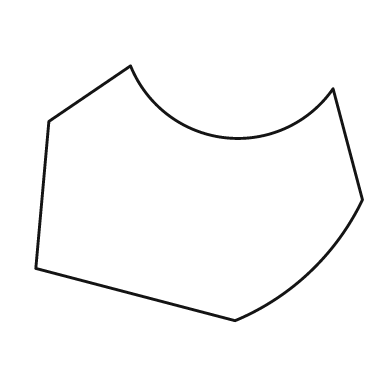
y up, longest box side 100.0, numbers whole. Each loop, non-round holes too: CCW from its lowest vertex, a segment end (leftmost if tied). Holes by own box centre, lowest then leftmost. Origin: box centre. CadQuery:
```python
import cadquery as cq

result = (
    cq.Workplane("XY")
    .moveTo(11.0, -39.0)
    .threePointArc((34.0, -24.0), (50.0, -2.0))
    .lineTo(41.0, 32.0)
    .threePointArc((8.0, 17.0), (-21.0, 39.0))
    .lineTo(-46.0, 22.0)
    .lineTo(-50.0, -23.0)
    .close()
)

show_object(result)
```